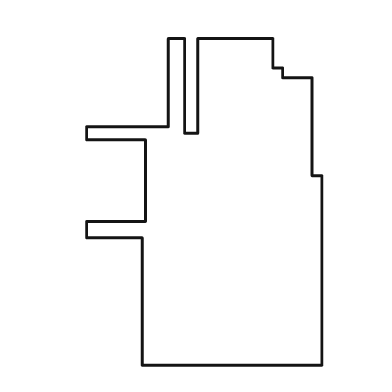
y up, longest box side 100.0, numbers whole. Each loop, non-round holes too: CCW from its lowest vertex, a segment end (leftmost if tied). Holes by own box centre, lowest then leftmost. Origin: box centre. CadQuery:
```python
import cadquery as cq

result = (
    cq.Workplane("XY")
    .moveTo(-19.0, -50.0)
    .lineTo(36.0, -50.0)
    .lineTo(36.0, 8.0)
    .lineTo(33.0, 8.0)
    .lineTo(33.0, 38.0)
    .lineTo(24.0, 38.0)
    .lineTo(24.0, 41.0)
    .lineTo(21.0, 41.0)
    .lineTo(21.0, 50.0)
    .lineTo(-2.0, 50.0)
    .lineTo(-2.0, 21.0)
    .lineTo(-6.0, 21.0)
    .lineTo(-6.0, 50.0)
    .lineTo(-11.0, 50.0)
    .lineTo(-11.0, 23.0)
    .lineTo(-36.0, 23.0)
    .lineTo(-36.0, 19.0)
    .lineTo(-18.0, 19.0)
    .lineTo(-18.0, -6.0)
    .lineTo(-36.0, -6.0)
    .lineTo(-36.0, -11.0)
    .lineTo(-19.0, -11.0)
    .close()
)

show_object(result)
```